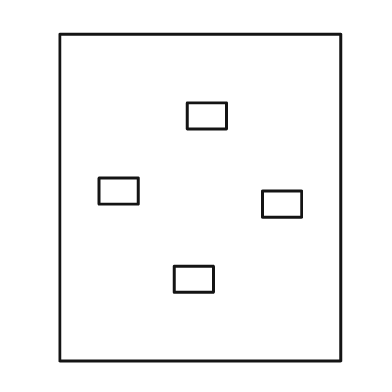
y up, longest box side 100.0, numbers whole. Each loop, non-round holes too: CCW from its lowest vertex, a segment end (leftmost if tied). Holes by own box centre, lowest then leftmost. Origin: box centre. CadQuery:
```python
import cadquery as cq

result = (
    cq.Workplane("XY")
    .moveTo(-43.0, -50.0)
    .lineTo(43.0, -50.0)
    .lineTo(43.0, 50.0)
    .lineTo(-43.0, 50.0)
    .close()
    .moveTo(-8.0, -29.0)
    .lineTo(4.0, -29.0)
    .lineTo(4.0, -21.0)
    .lineTo(-8.0, -21.0)
    .close()
    .moveTo(19.0, -6.0)
    .lineTo(31.0, -6.0)
    .lineTo(31.0, 2.0)
    .lineTo(19.0, 2.0)
    .close()
    .moveTo(-31.0, -2.0)
    .lineTo(-19.0, -2.0)
    .lineTo(-19.0, 6.0)
    .lineTo(-31.0, 6.0)
    .close()
    .moveTo(-4.0, 21.0)
    .lineTo(8.0, 21.0)
    .lineTo(8.0, 29.0)
    .lineTo(-4.0, 29.0)
    .close()
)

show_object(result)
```